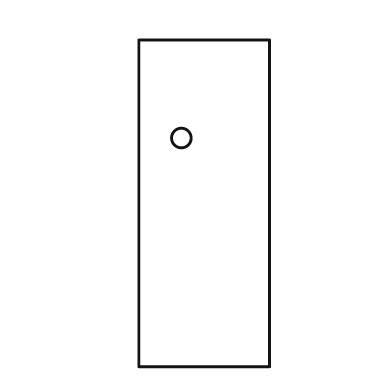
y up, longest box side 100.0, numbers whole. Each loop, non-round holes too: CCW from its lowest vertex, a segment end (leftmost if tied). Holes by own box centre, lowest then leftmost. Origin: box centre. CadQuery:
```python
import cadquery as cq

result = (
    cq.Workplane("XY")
    .moveTo(-20.0, -50.0)
    .lineTo(20.0, -50.0)
    .lineTo(20.0, 50.0)
    .lineTo(-20.0, 50.0)
    .close()
    .moveTo(-7.0, 20.0)
    .circle(3.0)
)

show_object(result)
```